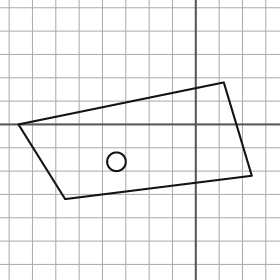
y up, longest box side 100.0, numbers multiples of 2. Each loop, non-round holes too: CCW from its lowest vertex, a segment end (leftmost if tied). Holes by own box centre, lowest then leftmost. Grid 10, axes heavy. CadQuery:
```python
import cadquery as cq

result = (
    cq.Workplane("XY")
    .moveTo(-56.0, -32.0)
    .lineTo(24.0, -22.0)
    .lineTo(12.0, 18.0)
    .lineTo(-76.0, 0.0)
    .close()
    .moveTo(-34.0, -16.0)
    .circle(4.0)
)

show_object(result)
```